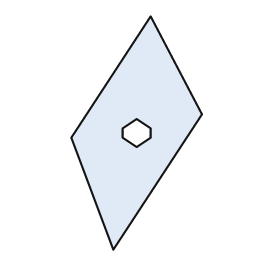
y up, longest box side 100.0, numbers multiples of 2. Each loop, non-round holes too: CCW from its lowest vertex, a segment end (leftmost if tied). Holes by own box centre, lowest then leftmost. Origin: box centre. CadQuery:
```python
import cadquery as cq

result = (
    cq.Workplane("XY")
    .moveTo(-10.0, -50.0)
    .lineTo(28.0, 8.0)
    .lineTo(6.0, 50.0)
    .lineTo(-28.0, -2.0)
    .close()
    .moveTo(0.0, -6.0)
    .lineTo(6.0, -2.0)
    .lineTo(6.0, 2.0)
    .lineTo(0.0, 6.0)
    .lineTo(-6.0, 2.0)
    .lineTo(-6.0, -2.0)
    .close()
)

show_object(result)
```